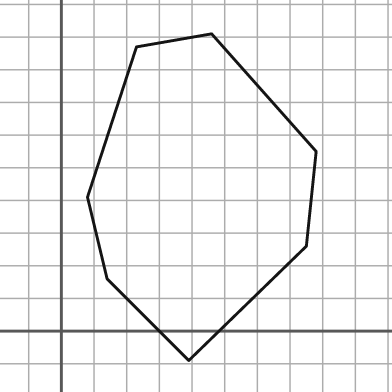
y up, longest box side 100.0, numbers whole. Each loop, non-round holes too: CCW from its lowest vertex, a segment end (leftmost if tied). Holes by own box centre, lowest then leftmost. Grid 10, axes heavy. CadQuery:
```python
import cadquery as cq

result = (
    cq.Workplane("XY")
    .moveTo(39.0, -9.0)
    .lineTo(75.0, 26.0)
    .lineTo(78.0, 55.0)
    .lineTo(46.0, 91.0)
    .lineTo(23.0, 87.0)
    .lineTo(8.0, 41.0)
    .lineTo(14.0, 16.0)
    .close()
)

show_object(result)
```